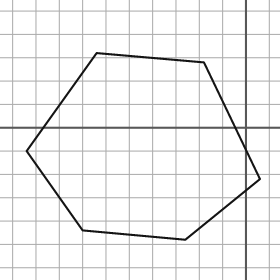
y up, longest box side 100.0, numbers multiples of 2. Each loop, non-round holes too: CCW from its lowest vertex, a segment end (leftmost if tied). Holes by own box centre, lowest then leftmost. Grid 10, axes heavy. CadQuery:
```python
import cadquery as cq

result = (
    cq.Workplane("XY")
    .moveTo(-26.0, -48.0)
    .lineTo(6.0, -22.0)
    .lineTo(-18.0, 28.0)
    .lineTo(-64.0, 32.0)
    .lineTo(-94.0, -10.0)
    .lineTo(-70.0, -44.0)
    .close()
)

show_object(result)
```